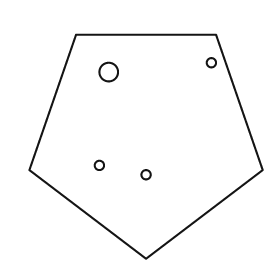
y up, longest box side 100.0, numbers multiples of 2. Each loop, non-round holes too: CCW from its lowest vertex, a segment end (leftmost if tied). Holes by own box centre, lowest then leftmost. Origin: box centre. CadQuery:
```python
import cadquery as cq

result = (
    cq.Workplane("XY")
    .moveTo(0.0, -48.0)
    .lineTo(50.0, -10.0)
    .lineTo(30.0, 48.0)
    .lineTo(-30.0, 48.0)
    .lineTo(-50.0, -10.0)
    .close()
    .moveTo(0.0, -12.0)
    .circle(2.0)
    .moveTo(-20.0, -8.0)
    .circle(2.0)
    .moveTo(-16.0, 32.0)
    .circle(4.0)
    .moveTo(28.0, 36.0)
    .circle(2.0)
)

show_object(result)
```